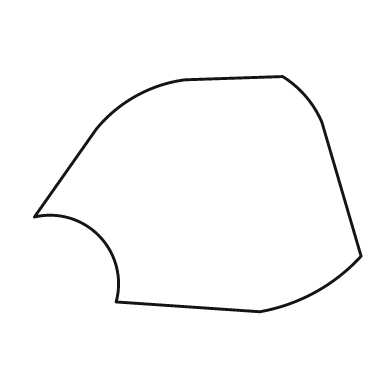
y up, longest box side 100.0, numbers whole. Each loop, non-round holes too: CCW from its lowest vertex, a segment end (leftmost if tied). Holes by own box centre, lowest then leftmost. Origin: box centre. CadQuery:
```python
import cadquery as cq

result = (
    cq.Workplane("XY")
    .moveTo(19.0, -36.0)
    .threePointArc((36.0, -30.0), (50.0, -19.0))
    .lineTo(38.0, 22.0)
    .threePointArc((33.0, 30.0), (26.0, 36.0))
    .lineTo(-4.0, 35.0)
    .threePointArc((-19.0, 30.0), (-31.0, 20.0))
    .lineTo(-50.0, -7.0)
    .threePointArc((-30.0, -13.0), (-25.0, -33.0))
    .close()
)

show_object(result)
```